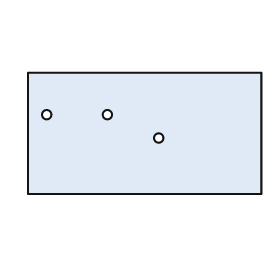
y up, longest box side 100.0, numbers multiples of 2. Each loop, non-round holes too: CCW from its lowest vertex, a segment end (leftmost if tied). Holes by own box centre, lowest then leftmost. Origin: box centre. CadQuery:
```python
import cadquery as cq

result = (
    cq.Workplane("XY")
    .moveTo(-50.0, -26.0)
    .lineTo(50.0, -26.0)
    .lineTo(50.0, 26.0)
    .lineTo(-50.0, 26.0)
    .close()
    .moveTo(6.0, -2.0)
    .circle(2.0)
    .moveTo(-42.0, 8.0)
    .circle(2.0)
    .moveTo(-16.0, 8.0)
    .circle(2.0)
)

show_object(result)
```